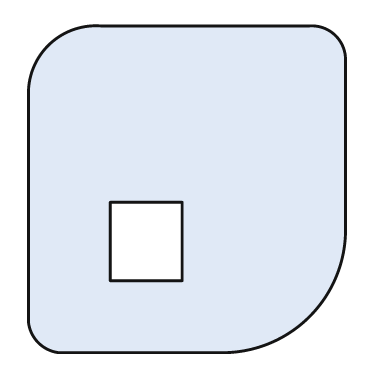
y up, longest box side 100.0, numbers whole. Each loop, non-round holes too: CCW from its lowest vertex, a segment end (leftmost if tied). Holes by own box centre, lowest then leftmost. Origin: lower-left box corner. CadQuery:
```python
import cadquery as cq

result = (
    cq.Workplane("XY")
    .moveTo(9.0, 0.0)
    .lineTo(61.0, 0.0)
    .threePointArc((86.0, 11.0), (97.0, 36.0))
    .lineTo(97.0, 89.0)
    .threePointArc((94.0, 97.0), (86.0, 100.0))
    .lineTo(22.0, 100.0)
    .threePointArc((6.0, 94.0), (0.0, 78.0))
    .lineTo(0.0, 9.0)
    .threePointArc((3.0, 3.0), (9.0, 0.0))
    .close()
    .moveTo(25.0, 22.0)
    .lineTo(47.0, 22.0)
    .lineTo(47.0, 46.0)
    .lineTo(25.0, 46.0)
    .close()
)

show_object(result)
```